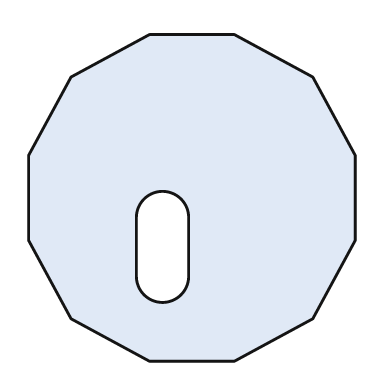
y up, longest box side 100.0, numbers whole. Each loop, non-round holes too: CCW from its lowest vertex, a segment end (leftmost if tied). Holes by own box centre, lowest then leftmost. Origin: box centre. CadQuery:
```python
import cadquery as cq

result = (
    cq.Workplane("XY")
    .moveTo(-13.0, -50.0)
    .lineTo(13.0, -50.0)
    .lineTo(37.0, -37.0)
    .lineTo(50.0, -13.0)
    .lineTo(50.0, 13.0)
    .lineTo(37.0, 37.0)
    .lineTo(13.0, 50.0)
    .lineTo(-13.0, 50.0)
    .lineTo(-37.0, 37.0)
    .lineTo(-50.0, 13.0)
    .lineTo(-50.0, -13.0)
    .lineTo(-37.0, -37.0)
    .close()
    .moveTo(-17.0, -24.0)
    .threePointArc((-9.0, -32.0), (-1.0, -24.0))
    .lineTo(-1.0, -6.0)
    .threePointArc((-9.0, 2.0), (-17.0, -6.0))
    .close()
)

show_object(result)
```